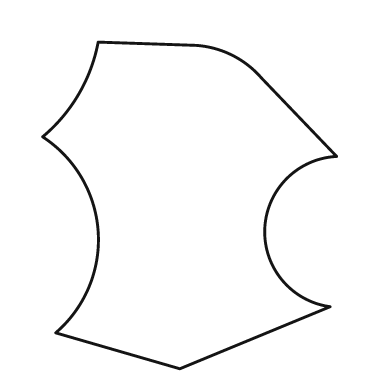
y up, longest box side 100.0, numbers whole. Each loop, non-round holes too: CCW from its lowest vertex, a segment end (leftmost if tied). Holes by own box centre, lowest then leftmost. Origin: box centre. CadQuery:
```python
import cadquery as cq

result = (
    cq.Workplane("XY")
    .moveTo(-3.0, -50.0)
    .lineTo(43.0, -31.0)
    .threePointArc((23.0, -7.0), (45.0, 15.0))
    .lineTo(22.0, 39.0)
    .threePointArc((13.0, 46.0), (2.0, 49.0))
    .lineTo(-28.0, 50.0)
    .threePointArc((-34.0, 34.0), (-45.0, 21.0))
    .threePointArc((-28.0, -8.0), (-41.0, -39.0))
    .close()
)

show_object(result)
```